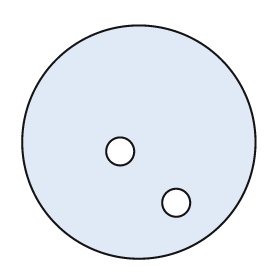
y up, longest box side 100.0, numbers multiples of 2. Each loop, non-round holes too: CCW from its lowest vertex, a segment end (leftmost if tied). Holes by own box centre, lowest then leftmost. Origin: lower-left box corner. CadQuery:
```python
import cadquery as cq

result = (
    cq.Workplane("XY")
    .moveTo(50.0, 50.0)
    .circle(50.0)
    .moveTo(66.0, 24.0)
    .circle(6.0)
    .moveTo(42.0, 46.0)
    .circle(6.0)
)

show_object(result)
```